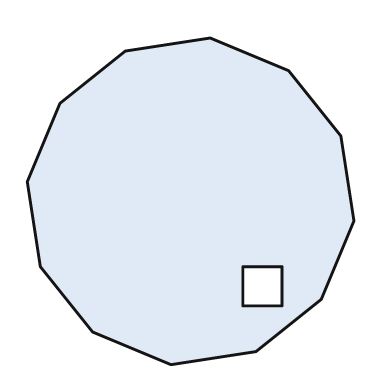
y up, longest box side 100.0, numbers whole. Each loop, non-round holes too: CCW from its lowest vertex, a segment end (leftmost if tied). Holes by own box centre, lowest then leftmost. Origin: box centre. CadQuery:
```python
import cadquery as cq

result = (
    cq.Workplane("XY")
    .moveTo(-6.0, -50.0)
    .lineTo(20.0, -46.0)
    .lineTo(40.0, -30.0)
    .lineTo(50.0, -6.0)
    .lineTo(46.0, 20.0)
    .lineTo(30.0, 40.0)
    .lineTo(6.0, 50.0)
    .lineTo(-20.0, 46.0)
    .lineTo(-40.0, 30.0)
    .lineTo(-50.0, 6.0)
    .lineTo(-46.0, -20.0)
    .lineTo(-30.0, -40.0)
    .close()
    .moveTo(16.0, -32.0)
    .lineTo(28.0, -32.0)
    .lineTo(28.0, -20.0)
    .lineTo(16.0, -20.0)
    .close()
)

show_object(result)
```